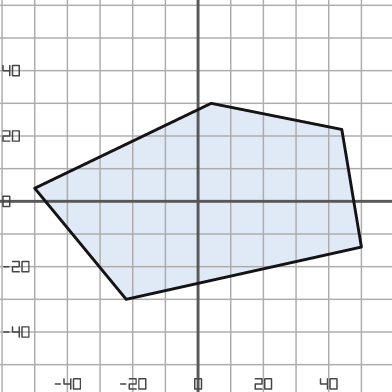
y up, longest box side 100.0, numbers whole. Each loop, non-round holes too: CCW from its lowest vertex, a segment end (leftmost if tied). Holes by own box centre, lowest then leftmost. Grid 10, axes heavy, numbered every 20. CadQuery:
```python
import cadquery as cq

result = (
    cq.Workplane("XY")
    .moveTo(-22.0, -30.0)
    .lineTo(50.0, -14.0)
    .lineTo(44.0, 22.0)
    .lineTo(4.0, 30.0)
    .lineTo(-50.0, 4.0)
    .close()
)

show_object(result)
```